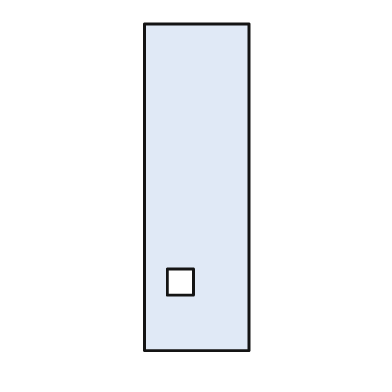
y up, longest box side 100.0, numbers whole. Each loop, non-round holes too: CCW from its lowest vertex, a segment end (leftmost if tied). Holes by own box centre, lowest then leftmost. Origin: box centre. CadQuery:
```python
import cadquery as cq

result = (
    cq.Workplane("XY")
    .moveTo(-16.0, -50.0)
    .lineTo(16.0, -50.0)
    .lineTo(16.0, 50.0)
    .lineTo(-16.0, 50.0)
    .close()
    .moveTo(-9.0, -33.0)
    .lineTo(-1.0, -33.0)
    .lineTo(-1.0, -25.0)
    .lineTo(-9.0, -25.0)
    .close()
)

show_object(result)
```